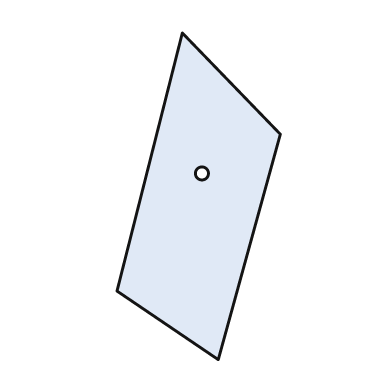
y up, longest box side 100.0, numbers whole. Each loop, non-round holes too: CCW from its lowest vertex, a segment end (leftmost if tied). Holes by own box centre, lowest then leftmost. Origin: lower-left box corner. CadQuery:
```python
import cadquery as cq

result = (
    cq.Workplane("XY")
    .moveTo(31.0, 0.0)
    .lineTo(50.0, 69.0)
    .lineTo(20.0, 100.0)
    .lineTo(0.0, 21.0)
    .close()
    .moveTo(26.0, 57.0)
    .circle(2.0)
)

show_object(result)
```